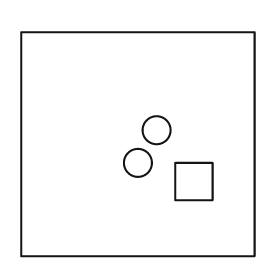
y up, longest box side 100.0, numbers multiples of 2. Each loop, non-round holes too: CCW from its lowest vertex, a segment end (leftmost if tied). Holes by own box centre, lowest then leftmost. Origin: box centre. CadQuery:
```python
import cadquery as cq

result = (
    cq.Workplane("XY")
    .moveTo(-50.0, -48.0)
    .lineTo(50.0, -48.0)
    .lineTo(50.0, 48.0)
    .lineTo(-50.0, 48.0)
    .close()
    .moveTo(16.0, -24.0)
    .lineTo(32.0, -24.0)
    .lineTo(32.0, -8.0)
    .lineTo(16.0, -8.0)
    .close()
    .moveTo(0.0, -8.0)
    .circle(6.0)
    .moveTo(8.0, 6.0)
    .circle(6.0)
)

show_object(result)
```